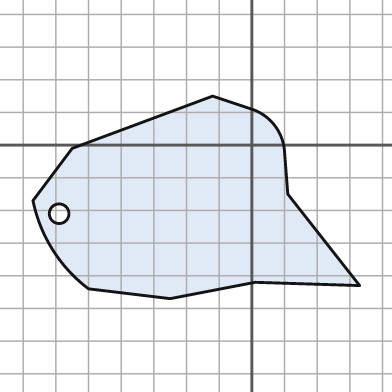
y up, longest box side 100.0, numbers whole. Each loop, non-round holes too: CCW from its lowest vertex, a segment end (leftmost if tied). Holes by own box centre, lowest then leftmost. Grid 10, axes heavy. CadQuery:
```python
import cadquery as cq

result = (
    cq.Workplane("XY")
    .moveTo(-25.0, -47.0)
    .lineTo(1.0, -42.0)
    .lineTo(33.0, -43.0)
    .lineTo(11.0, -15.0)
    .lineTo(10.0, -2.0)
    .threePointArc((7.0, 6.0), (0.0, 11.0))
    .lineTo(-12.0, 15.0)
    .lineTo(-55.0, -1.0)
    .lineTo(-67.0, -17.0)
    .threePointArc((-61.0, -32.0), (-50.0, -44.0))
    .close()
    .moveTo(-59.0, -21.0)
    .circle(3.0)
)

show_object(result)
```